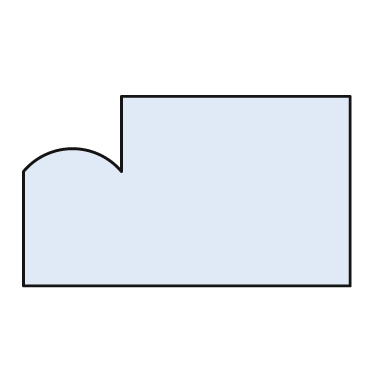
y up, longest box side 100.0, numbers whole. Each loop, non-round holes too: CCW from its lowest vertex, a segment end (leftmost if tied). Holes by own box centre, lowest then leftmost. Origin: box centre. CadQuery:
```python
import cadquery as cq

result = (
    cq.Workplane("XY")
    .moveTo(-50.0, -29.0)
    .lineTo(50.0, -29.0)
    .lineTo(50.0, 29.0)
    .lineTo(-20.0, 29.0)
    .lineTo(-20.0, 6.0)
    .threePointArc((-35.0, 13.0), (-50.0, 6.0))
    .close()
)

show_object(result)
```